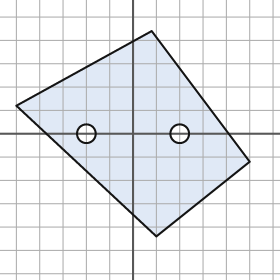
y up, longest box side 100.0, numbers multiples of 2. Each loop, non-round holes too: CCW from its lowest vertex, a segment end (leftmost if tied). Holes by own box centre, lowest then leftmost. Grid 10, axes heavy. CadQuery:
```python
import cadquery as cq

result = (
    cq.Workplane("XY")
    .moveTo(10.0, -44.0)
    .lineTo(50.0, -12.0)
    .lineTo(8.0, 44.0)
    .lineTo(-50.0, 12.0)
    .close()
    .moveTo(-20.0, 0.0)
    .circle(4.0)
    .moveTo(20.0, 0.0)
    .circle(4.0)
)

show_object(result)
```